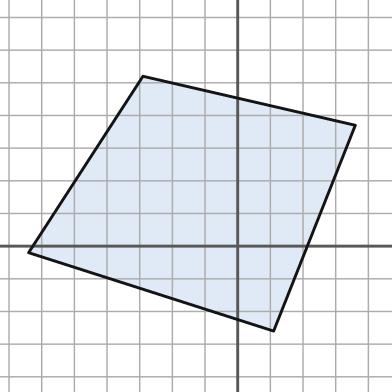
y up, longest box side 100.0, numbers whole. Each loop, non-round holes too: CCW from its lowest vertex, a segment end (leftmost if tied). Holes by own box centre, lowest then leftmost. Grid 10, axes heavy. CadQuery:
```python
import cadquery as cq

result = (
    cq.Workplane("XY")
    .moveTo(11.0, -26.0)
    .lineTo(36.0, 37.0)
    .lineTo(-29.0, 52.0)
    .lineTo(-64.0, -2.0)
    .close()
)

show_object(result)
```